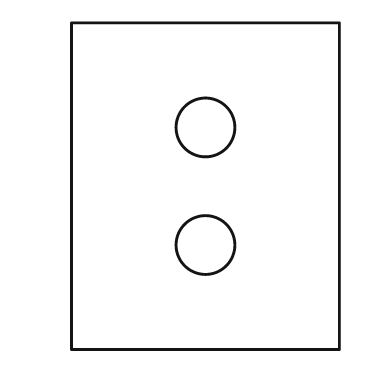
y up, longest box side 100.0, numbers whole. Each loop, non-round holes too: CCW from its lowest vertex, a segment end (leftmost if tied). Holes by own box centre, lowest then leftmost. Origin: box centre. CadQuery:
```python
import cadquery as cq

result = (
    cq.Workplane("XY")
    .moveTo(-41.0, -50.0)
    .lineTo(41.0, -50.0)
    .lineTo(41.0, 50.0)
    .lineTo(-41.0, 50.0)
    .close()
    .moveTo(0.0, -18.0)
    .circle(9.0)
    .moveTo(0.0, 18.0)
    .circle(9.0)
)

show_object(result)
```